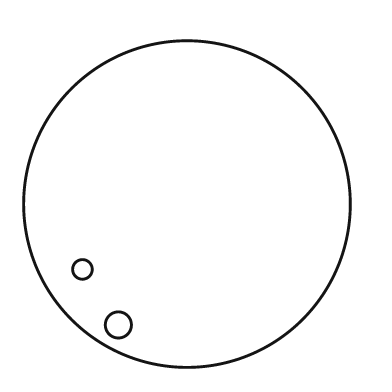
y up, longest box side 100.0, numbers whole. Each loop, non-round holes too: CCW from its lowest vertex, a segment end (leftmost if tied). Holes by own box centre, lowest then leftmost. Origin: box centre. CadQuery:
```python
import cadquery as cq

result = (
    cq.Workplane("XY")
    .moveTo(0.0, 0.0)
    .circle(50.0)
    .moveTo(-21.0, -37.0)
    .circle(4.0)
    .moveTo(-32.0, -20.0)
    .circle(3.0)
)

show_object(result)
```